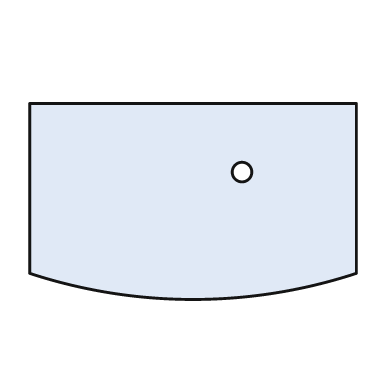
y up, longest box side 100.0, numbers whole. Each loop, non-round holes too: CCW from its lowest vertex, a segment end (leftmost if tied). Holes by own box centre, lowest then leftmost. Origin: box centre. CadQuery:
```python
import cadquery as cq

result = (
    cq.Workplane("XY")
    .moveTo(-50.0, -22.0)
    .threePointArc((0.0, -30.0), (50.0, -22.0))
    .lineTo(50.0, 30.0)
    .lineTo(-50.0, 30.0)
    .close()
    .moveTo(15.0, 9.0)
    .circle(3.0)
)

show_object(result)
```